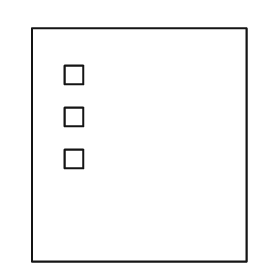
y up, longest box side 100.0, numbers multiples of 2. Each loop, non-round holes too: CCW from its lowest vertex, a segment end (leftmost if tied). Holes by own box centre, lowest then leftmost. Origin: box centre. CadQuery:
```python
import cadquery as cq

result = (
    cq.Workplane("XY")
    .moveTo(-46.0, -50.0)
    .lineTo(46.0, -50.0)
    .lineTo(46.0, 50.0)
    .lineTo(-46.0, 50.0)
    .close()
    .moveTo(-32.0, -10.0)
    .lineTo(-24.0, -10.0)
    .lineTo(-24.0, -2.0)
    .lineTo(-32.0, -2.0)
    .close()
    .moveTo(-32.0, 8.0)
    .lineTo(-24.0, 8.0)
    .lineTo(-24.0, 16.0)
    .lineTo(-32.0, 16.0)
    .close()
    .moveTo(-32.0, 26.0)
    .lineTo(-24.0, 26.0)
    .lineTo(-24.0, 34.0)
    .lineTo(-32.0, 34.0)
    .close()
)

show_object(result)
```